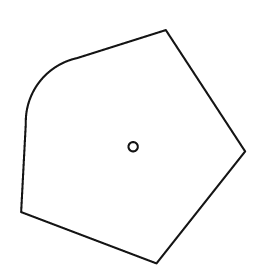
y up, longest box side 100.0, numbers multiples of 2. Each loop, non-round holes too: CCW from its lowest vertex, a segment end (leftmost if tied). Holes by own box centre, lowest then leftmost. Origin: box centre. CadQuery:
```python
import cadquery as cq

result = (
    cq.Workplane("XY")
    .moveTo(10.0, -50.0)
    .lineTo(48.0, -2.0)
    .lineTo(14.0, 50.0)
    .lineTo(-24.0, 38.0)
    .threePointArc((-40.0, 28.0), (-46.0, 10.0))
    .lineTo(-48.0, -28.0)
    .close()
    .moveTo(0.0, 0.0)
    .circle(2.0)
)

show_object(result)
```